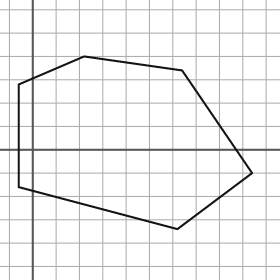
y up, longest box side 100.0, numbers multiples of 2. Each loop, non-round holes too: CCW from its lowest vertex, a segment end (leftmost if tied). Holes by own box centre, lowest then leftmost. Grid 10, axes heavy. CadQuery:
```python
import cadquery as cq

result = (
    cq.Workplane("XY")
    .moveTo(62.0, -34.0)
    .lineTo(94.0, -10.0)
    .lineTo(64.0, 34.0)
    .lineTo(22.0, 40.0)
    .lineTo(-6.0, 28.0)
    .lineTo(-6.0, -16.0)
    .close()
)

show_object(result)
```